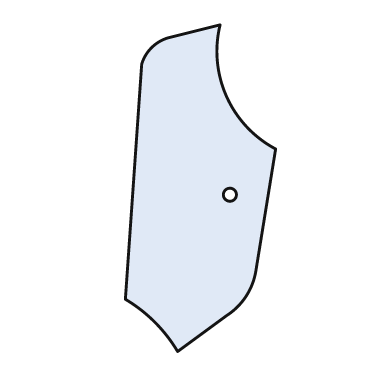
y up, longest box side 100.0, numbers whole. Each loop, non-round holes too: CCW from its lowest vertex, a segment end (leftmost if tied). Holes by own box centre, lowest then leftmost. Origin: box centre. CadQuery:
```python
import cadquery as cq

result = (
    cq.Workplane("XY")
    .moveTo(-7.0, -50.0)
    .lineTo(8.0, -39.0)
    .threePointArc((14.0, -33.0), (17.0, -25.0))
    .lineTo(23.0, 12.0)
    .threePointArc((8.0, 28.0), (6.0, 50.0))
    .lineTo(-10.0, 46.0)
    .threePointArc((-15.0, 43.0), (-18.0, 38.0))
    .lineTo(-23.0, -34.0)
    .threePointArc((-14.0, -41.0), (-7.0, -50.0))
    .close()
    .moveTo(9.0, -2.0)
    .circle(2.0)
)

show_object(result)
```